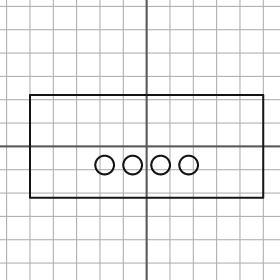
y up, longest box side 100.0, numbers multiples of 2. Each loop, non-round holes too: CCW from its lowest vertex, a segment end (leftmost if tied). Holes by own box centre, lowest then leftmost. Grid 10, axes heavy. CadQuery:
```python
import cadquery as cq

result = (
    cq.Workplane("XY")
    .moveTo(-50.0, -22.0)
    .lineTo(50.0, -22.0)
    .lineTo(50.0, 22.0)
    .lineTo(-50.0, 22.0)
    .close()
    .moveTo(-18.0, -8.0)
    .circle(4.0)
    .moveTo(-6.0, -8.0)
    .circle(4.0)
    .moveTo(6.0, -8.0)
    .circle(4.0)
    .moveTo(18.0, -8.0)
    .circle(4.0)
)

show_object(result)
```